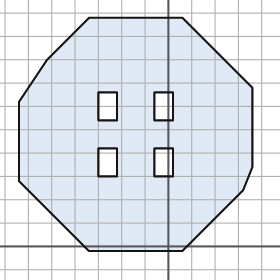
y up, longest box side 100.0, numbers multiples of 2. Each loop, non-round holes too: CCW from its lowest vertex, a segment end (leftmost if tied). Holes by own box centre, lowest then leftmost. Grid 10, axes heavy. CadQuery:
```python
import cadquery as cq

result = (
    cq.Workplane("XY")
    .moveTo(-34.0, -2.0)
    .lineTo(6.0, -2.0)
    .lineTo(32.0, 24.0)
    .lineTo(36.0, 34.0)
    .lineTo(36.0, 68.0)
    .lineTo(6.0, 98.0)
    .lineTo(-34.0, 98.0)
    .lineTo(-52.0, 80.0)
    .lineTo(-64.0, 62.0)
    .lineTo(-64.0, 28.0)
    .close()
    .moveTo(-30.0, 30.0)
    .lineTo(-22.0, 30.0)
    .lineTo(-22.0, 42.0)
    .lineTo(-30.0, 42.0)
    .close()
    .moveTo(-6.0, 30.0)
    .lineTo(2.0, 30.0)
    .lineTo(2.0, 42.0)
    .lineTo(-6.0, 42.0)
    .close()
    .moveTo(-30.0, 54.0)
    .lineTo(-22.0, 54.0)
    .lineTo(-22.0, 66.0)
    .lineTo(-30.0, 66.0)
    .close()
    .moveTo(-6.0, 54.0)
    .lineTo(2.0, 54.0)
    .lineTo(2.0, 66.0)
    .lineTo(-6.0, 66.0)
    .close()
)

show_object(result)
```